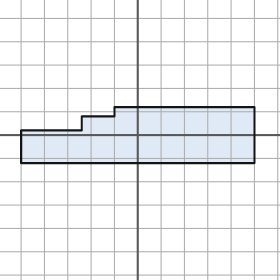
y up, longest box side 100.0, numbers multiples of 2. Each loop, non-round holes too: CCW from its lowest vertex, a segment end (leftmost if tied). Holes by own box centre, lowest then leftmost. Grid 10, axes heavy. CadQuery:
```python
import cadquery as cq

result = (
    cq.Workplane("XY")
    .moveTo(-50.0, -12.0)
    .lineTo(50.0, -12.0)
    .lineTo(50.0, 12.0)
    .lineTo(-10.0, 12.0)
    .lineTo(-10.0, 8.0)
    .lineTo(-24.0, 8.0)
    .lineTo(-24.0, 2.0)
    .lineTo(-50.0, 2.0)
    .close()
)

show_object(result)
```